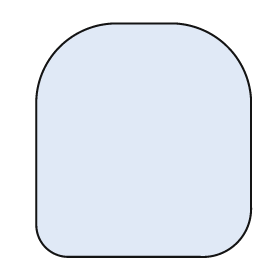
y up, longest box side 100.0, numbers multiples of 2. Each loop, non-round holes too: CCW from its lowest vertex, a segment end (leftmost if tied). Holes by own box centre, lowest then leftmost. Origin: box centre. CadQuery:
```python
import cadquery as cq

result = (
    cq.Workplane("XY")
    .moveTo(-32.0, -50.0)
    .lineTo(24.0, -50.0)
    .threePointArc((40.0, -44.0), (46.0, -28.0))
    .lineTo(46.0, 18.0)
    .threePointArc((36.0, 40.0), (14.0, 50.0))
    .lineTo(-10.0, 50.0)
    .threePointArc((-36.0, 40.0), (-46.0, 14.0))
    .lineTo(-46.0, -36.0)
    .threePointArc((-42.0, -46.0), (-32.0, -50.0))
    .close()
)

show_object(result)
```